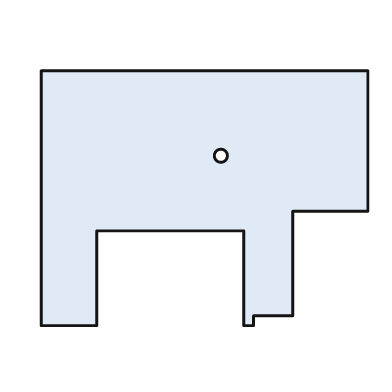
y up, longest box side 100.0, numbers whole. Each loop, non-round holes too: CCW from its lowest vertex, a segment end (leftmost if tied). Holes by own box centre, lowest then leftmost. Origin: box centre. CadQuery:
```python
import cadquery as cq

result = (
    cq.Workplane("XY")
    .moveTo(-50.0, -39.0)
    .lineTo(-33.0, -39.0)
    .lineTo(-33.0, -10.0)
    .lineTo(12.0, -10.0)
    .lineTo(12.0, -39.0)
    .lineTo(15.0, -39.0)
    .lineTo(15.0, -36.0)
    .lineTo(27.0, -36.0)
    .lineTo(27.0, -4.0)
    .lineTo(50.0, -4.0)
    .lineTo(50.0, 39.0)
    .lineTo(-50.0, 39.0)
    .close()
    .moveTo(5.0, 13.0)
    .circle(2.0)
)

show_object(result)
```